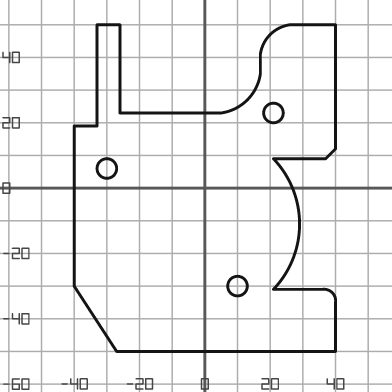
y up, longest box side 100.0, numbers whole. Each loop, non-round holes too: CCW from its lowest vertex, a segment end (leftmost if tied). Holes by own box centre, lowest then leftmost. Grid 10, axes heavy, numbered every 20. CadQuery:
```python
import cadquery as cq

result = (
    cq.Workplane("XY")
    .moveTo(-27.0, -50.0)
    .lineTo(40.0, -50.0)
    .lineTo(40.0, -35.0)
    .threePointArc((39.0, -32.0), (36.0, -31.0))
    .lineTo(21.0, -31.0)
    .threePointArc((29.0, -11.0), (21.0, 9.0))
    .lineTo(37.0, 9.0)
    .lineTo(40.0, 12.0)
    .lineTo(40.0, 50.0)
    .lineTo(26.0, 50.0)
    .threePointArc((20.0, 47.0), (17.0, 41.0))
    .lineTo(17.0, 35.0)
    .threePointArc((13.0, 27.0), (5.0, 23.0))
    .lineTo(-26.0, 23.0)
    .lineTo(-26.0, 50.0)
    .lineTo(-33.0, 50.0)
    .lineTo(-33.0, 19.0)
    .lineTo(-40.0, 19.0)
    .lineTo(-40.0, -30.0)
    .close()
    .moveTo(10.0, -30.0)
    .circle(3.0)
    .moveTo(-30.0, 6.0)
    .circle(3.0)
    .moveTo(21.0, 23.0)
    .circle(3.0)
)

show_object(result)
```